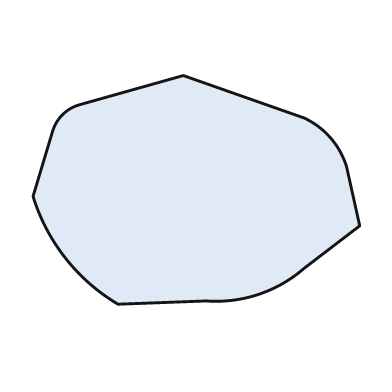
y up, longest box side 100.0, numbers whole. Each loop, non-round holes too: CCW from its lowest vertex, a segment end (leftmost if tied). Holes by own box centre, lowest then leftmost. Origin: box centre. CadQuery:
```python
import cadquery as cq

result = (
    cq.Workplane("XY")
    .moveTo(-24.0, -35.0)
    .lineTo(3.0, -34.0)
    .threePointArc((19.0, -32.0), (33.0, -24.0))
    .lineTo(50.0, -11.0)
    .lineTo(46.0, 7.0)
    .threePointArc((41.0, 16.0), (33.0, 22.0))
    .lineTo(-4.0, 35.0)
    .lineTo(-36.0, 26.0)
    .threePointArc((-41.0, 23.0), (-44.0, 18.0))
    .lineTo(-50.0, -2.0)
    .threePointArc((-40.0, -21.0), (-24.0, -35.0))
    .close()
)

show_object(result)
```